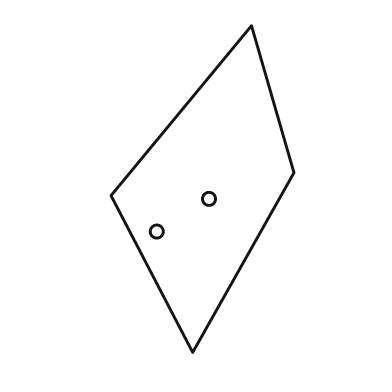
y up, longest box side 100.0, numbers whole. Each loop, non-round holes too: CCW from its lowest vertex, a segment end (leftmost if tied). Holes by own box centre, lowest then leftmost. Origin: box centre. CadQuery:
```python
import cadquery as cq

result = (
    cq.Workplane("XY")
    .moveTo(-3.0, -50.0)
    .lineTo(28.0, 5.0)
    .lineTo(15.0, 50.0)
    .lineTo(-28.0, -2.0)
    .close()
    .moveTo(-14.0, -13.0)
    .circle(2.0)
    .moveTo(2.0, -3.0)
    .circle(2.0)
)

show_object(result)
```